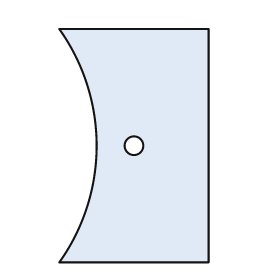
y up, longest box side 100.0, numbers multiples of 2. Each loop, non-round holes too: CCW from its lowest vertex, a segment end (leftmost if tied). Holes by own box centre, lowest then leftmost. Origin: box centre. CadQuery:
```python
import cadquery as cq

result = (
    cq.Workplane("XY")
    .moveTo(-32.0, -50.0)
    .lineTo(32.0, -50.0)
    .lineTo(32.0, 50.0)
    .lineTo(-32.0, 50.0)
    .threePointArc((-16.0, 0.0), (-32.0, -50.0))
    .close()
    .moveTo(0.0, 0.0)
    .circle(4.0)
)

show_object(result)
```